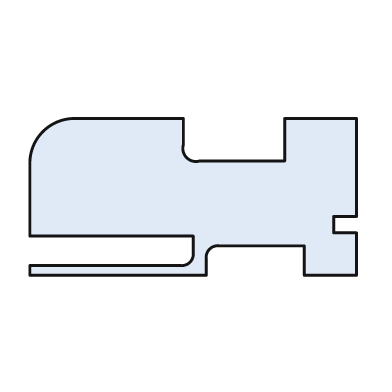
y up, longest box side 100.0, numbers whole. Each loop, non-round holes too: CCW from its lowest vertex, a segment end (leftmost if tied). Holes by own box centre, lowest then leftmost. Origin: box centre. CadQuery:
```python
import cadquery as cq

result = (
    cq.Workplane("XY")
    .moveTo(-50.0, -24.0)
    .lineTo(4.0, -24.0)
    .lineTo(4.0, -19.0)
    .threePointArc((5.0, -16.0), (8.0, -15.0))
    .lineTo(34.0, -15.0)
    .lineTo(34.0, -24.0)
    .lineTo(50.0, -24.0)
    .lineTo(50.0, -11.0)
    .lineTo(43.0, -11.0)
    .lineTo(43.0, -6.0)
    .lineTo(50.0, -6.0)
    .lineTo(50.0, 24.0)
    .lineTo(28.0, 24.0)
    .lineTo(28.0, 11.0)
    .lineTo(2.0, 11.0)
    .threePointArc((-2.0, 12.0), (-3.0, 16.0))
    .lineTo(-3.0, 24.0)
    .lineTo(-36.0, 24.0)
    .threePointArc((-46.0, 20.0), (-50.0, 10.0))
    .lineTo(-50.0, -12.0)
    .lineTo(0.0, -12.0)
    .lineTo(0.0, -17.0)
    .threePointArc((-1.0, -20.0), (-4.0, -21.0))
    .lineTo(-50.0, -21.0)
    .close()
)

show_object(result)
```